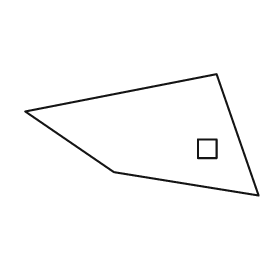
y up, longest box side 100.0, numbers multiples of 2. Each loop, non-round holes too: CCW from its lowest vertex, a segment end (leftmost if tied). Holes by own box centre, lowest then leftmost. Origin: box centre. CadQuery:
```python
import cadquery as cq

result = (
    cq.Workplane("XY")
    .moveTo(50.0, -26.0)
    .lineTo(32.0, 26.0)
    .lineTo(-50.0, 10.0)
    .lineTo(-12.0, -16.0)
    .close()
    .moveTo(24.0, -10.0)
    .lineTo(32.0, -10.0)
    .lineTo(32.0, -2.0)
    .lineTo(24.0, -2.0)
    .close()
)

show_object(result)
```